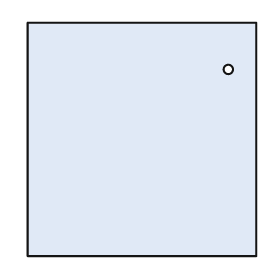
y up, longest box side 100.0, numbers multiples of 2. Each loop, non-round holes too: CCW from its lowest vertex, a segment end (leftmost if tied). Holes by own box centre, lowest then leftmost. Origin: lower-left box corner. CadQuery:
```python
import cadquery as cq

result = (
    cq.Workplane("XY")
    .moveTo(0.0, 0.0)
    .lineTo(98.0, 0.0)
    .lineTo(98.0, 100.0)
    .lineTo(0.0, 100.0)
    .close()
    .moveTo(86.0, 80.0)
    .circle(2.0)
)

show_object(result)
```